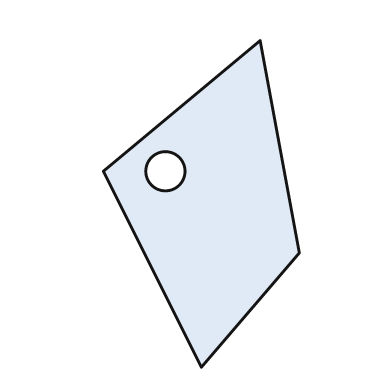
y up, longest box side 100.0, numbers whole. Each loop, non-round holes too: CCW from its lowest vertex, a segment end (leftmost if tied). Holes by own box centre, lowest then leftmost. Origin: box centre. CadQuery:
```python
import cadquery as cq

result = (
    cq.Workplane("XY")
    .moveTo(0.0, -50.0)
    .lineTo(30.0, -15.0)
    .lineTo(18.0, 50.0)
    .lineTo(-30.0, 10.0)
    .close()
    .moveTo(-11.0, 10.0)
    .circle(6.0)
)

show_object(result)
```